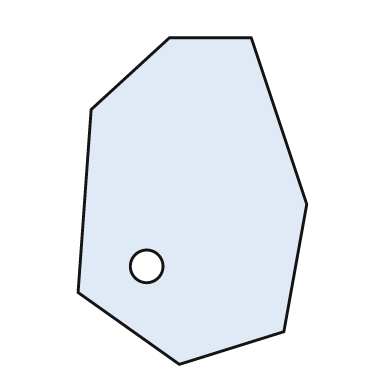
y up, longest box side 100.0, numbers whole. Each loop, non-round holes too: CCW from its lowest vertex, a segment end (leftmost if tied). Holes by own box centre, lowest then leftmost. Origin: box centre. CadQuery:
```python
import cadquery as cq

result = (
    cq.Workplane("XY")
    .moveTo(-4.0, -50.0)
    .lineTo(28.0, -40.0)
    .lineTo(35.0, -1.0)
    .lineTo(18.0, 50.0)
    .lineTo(-7.0, 50.0)
    .lineTo(-31.0, 28.0)
    .lineTo(-35.0, -28.0)
    .close()
    .moveTo(-14.0, -20.0)
    .circle(5.0)
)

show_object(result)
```